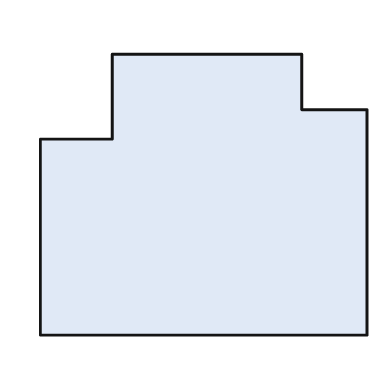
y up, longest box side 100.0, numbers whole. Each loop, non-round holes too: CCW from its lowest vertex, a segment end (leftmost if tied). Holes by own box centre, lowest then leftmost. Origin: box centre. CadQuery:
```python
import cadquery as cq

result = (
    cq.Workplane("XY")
    .moveTo(-50.0, -43.0)
    .lineTo(50.0, -43.0)
    .lineTo(50.0, 26.0)
    .lineTo(30.0, 26.0)
    .lineTo(30.0, 43.0)
    .lineTo(-28.0, 43.0)
    .lineTo(-28.0, 17.0)
    .lineTo(-50.0, 17.0)
    .close()
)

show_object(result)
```